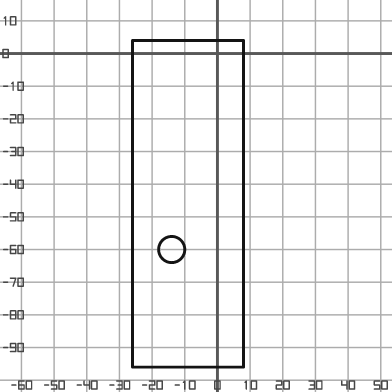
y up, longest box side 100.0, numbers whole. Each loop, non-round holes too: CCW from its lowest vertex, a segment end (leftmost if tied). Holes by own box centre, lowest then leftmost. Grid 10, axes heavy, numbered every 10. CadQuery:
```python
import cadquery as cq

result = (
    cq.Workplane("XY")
    .moveTo(-26.0, -96.0)
    .lineTo(8.0, -96.0)
    .lineTo(8.0, 4.0)
    .lineTo(-26.0, 4.0)
    .close()
    .moveTo(-14.0, -60.0)
    .circle(4.0)
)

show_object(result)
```